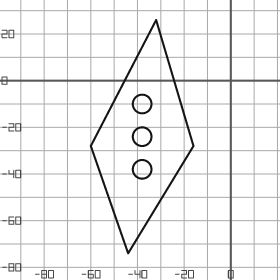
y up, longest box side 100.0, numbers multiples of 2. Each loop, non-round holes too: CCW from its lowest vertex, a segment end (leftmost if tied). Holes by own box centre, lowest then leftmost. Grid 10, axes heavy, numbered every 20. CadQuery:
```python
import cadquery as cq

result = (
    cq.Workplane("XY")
    .moveTo(-44.0, -74.0)
    .lineTo(-16.0, -28.0)
    .lineTo(-32.0, 26.0)
    .lineTo(-60.0, -28.0)
    .close()
    .moveTo(-38.0, -38.0)
    .circle(4.0)
    .moveTo(-38.0, -24.0)
    .circle(4.0)
    .moveTo(-38.0, -10.0)
    .circle(4.0)
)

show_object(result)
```